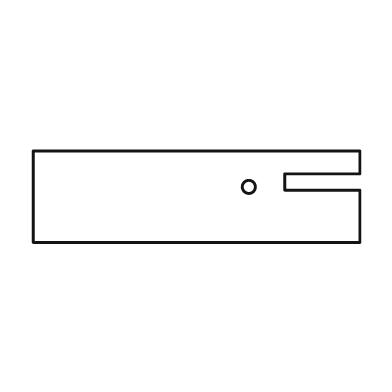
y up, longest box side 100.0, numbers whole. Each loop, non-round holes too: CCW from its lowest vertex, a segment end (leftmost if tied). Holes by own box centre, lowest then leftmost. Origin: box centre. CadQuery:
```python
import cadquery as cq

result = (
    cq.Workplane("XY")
    .moveTo(-50.0, -14.0)
    .lineTo(50.0, -14.0)
    .lineTo(50.0, 2.0)
    .lineTo(27.0, 2.0)
    .lineTo(27.0, 7.0)
    .lineTo(50.0, 7.0)
    .lineTo(50.0, 14.0)
    .lineTo(-50.0, 14.0)
    .close()
    .moveTo(16.0, 3.0)
    .circle(2.0)
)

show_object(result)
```